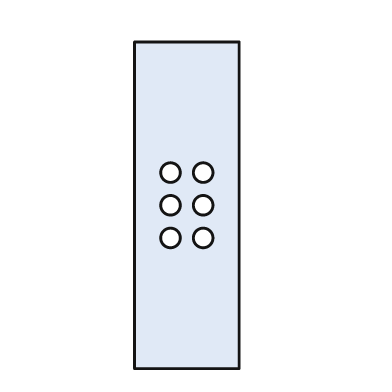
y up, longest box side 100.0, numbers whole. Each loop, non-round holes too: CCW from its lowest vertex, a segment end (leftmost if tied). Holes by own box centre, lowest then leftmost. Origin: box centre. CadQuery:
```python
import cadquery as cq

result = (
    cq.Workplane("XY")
    .moveTo(-16.0, -50.0)
    .lineTo(16.0, -50.0)
    .lineTo(16.0, 50.0)
    .lineTo(-16.0, 50.0)
    .close()
    .moveTo(-5.0, -10.0)
    .circle(3.0)
    .moveTo(5.0, -10.0)
    .circle(3.0)
    .moveTo(-5.0, 0.0)
    .circle(3.0)
    .moveTo(5.0, 0.0)
    .circle(3.0)
    .moveTo(-5.0, 10.0)
    .circle(3.0)
    .moveTo(5.0, 10.0)
    .circle(3.0)
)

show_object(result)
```